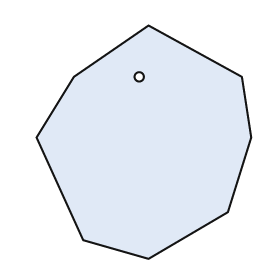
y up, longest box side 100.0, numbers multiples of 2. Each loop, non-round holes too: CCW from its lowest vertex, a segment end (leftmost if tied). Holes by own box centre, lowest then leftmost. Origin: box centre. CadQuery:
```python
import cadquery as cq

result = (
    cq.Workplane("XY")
    .moveTo(2.0, -50.0)
    .lineTo(36.0, -30.0)
    .lineTo(46.0, 2.0)
    .lineTo(42.0, 28.0)
    .lineTo(2.0, 50.0)
    .lineTo(-30.0, 28.0)
    .lineTo(-46.0, 2.0)
    .lineTo(-26.0, -42.0)
    .close()
    .moveTo(-2.0, 28.0)
    .circle(2.0)
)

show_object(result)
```